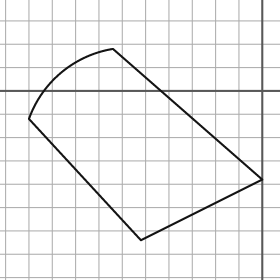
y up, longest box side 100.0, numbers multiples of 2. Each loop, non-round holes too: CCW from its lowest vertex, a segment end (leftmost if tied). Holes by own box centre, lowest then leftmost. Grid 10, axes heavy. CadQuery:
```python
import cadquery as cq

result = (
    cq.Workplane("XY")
    .moveTo(-52.0, -64.0)
    .lineTo(0.0, -38.0)
    .lineTo(-64.0, 18.0)
    .threePointArc((-86.0, 8.0), (-100.0, -12.0))
    .close()
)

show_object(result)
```